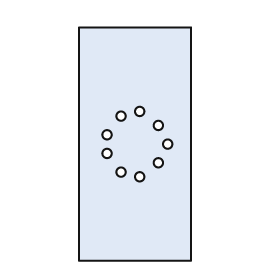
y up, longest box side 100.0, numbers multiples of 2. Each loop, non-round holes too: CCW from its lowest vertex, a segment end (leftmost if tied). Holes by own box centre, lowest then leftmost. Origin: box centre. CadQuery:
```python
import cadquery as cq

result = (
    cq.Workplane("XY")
    .moveTo(-24.0, -50.0)
    .lineTo(24.0, -50.0)
    .lineTo(24.0, 50.0)
    .lineTo(-24.0, 50.0)
    .close()
    .moveTo(2.0, -14.0)
    .circle(2.0)
    .moveTo(-6.0, -12.0)
    .circle(2.0)
    .moveTo(10.0, -8.0)
    .circle(2.0)
    .moveTo(-12.0, -4.0)
    .circle(2.0)
    .moveTo(14.0, 0.0)
    .circle(2.0)
    .moveTo(-12.0, 4.0)
    .circle(2.0)
    .moveTo(10.0, 8.0)
    .circle(2.0)
    .moveTo(-6.0, 12.0)
    .circle(2.0)
    .moveTo(2.0, 14.0)
    .circle(2.0)
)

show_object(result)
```